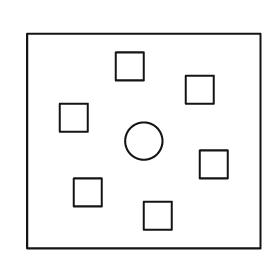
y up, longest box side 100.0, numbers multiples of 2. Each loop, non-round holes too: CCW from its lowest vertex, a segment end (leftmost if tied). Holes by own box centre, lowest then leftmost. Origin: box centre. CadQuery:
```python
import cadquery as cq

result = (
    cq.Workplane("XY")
    .moveTo(-50.0, -46.0)
    .lineTo(50.0, -46.0)
    .lineTo(50.0, 46.0)
    .lineTo(-50.0, 46.0)
    .close()
    .moveTo(0.0, -38.0)
    .lineTo(12.0, -38.0)
    .lineTo(12.0, -26.0)
    .lineTo(0.0, -26.0)
    .close()
    .moveTo(-30.0, -28.0)
    .lineTo(-18.0, -28.0)
    .lineTo(-18.0, -16.0)
    .lineTo(-30.0, -16.0)
    .close()
    .moveTo(24.0, -16.0)
    .lineTo(36.0, -16.0)
    .lineTo(36.0, -4.0)
    .lineTo(24.0, -4.0)
    .close()
    .moveTo(0.0, 0.0)
    .circle(8.0)
    .moveTo(-36.0, 4.0)
    .lineTo(-24.0, 4.0)
    .lineTo(-24.0, 16.0)
    .lineTo(-36.0, 16.0)
    .close()
    .moveTo(18.0, 16.0)
    .lineTo(30.0, 16.0)
    .lineTo(30.0, 28.0)
    .lineTo(18.0, 28.0)
    .close()
    .moveTo(-12.0, 26.0)
    .lineTo(0.0, 26.0)
    .lineTo(0.0, 38.0)
    .lineTo(-12.0, 38.0)
    .close()
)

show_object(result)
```